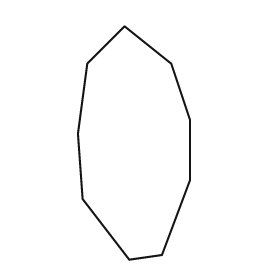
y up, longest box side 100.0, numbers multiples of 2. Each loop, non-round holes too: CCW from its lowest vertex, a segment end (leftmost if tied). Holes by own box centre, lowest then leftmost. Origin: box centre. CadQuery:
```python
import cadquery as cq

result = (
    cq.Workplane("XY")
    .moveTo(-2.0, -50.0)
    .lineTo(12.0, -48.0)
    .lineTo(24.0, -16.0)
    .lineTo(24.0, 10.0)
    .lineTo(16.0, 34.0)
    .lineTo(-4.0, 50.0)
    .lineTo(-20.0, 34.0)
    .lineTo(-24.0, 4.0)
    .lineTo(-22.0, -24.0)
    .close()
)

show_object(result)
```